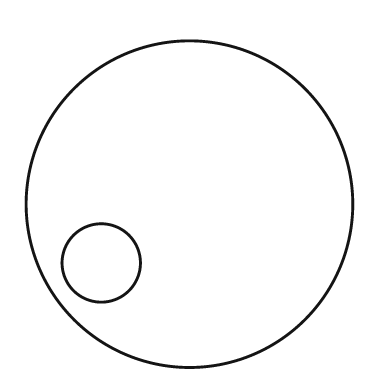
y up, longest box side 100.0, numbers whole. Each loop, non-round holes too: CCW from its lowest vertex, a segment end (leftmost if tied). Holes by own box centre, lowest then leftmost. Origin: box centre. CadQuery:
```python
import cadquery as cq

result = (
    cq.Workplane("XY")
    .moveTo(0.0, 0.0)
    .circle(50.0)
    .moveTo(-27.0, -18.0)
    .circle(12.0)
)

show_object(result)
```